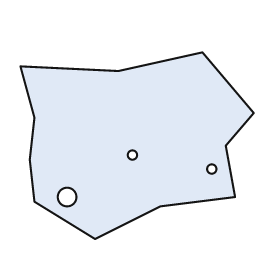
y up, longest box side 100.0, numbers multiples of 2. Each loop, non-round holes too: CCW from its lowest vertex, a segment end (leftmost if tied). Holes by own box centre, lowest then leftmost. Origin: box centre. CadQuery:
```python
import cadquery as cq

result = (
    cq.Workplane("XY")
    .moveTo(-18.0, -40.0)
    .lineTo(10.0, -26.0)
    .lineTo(42.0, -22.0)
    .lineTo(38.0, 0.0)
    .lineTo(50.0, 14.0)
    .lineTo(28.0, 40.0)
    .lineTo(-8.0, 32.0)
    .lineTo(-50.0, 34.0)
    .lineTo(-44.0, 12.0)
    .lineTo(-46.0, -6.0)
    .lineTo(-44.0, -24.0)
    .close()
    .moveTo(-30.0, -22.0)
    .circle(4.0)
    .moveTo(32.0, -10.0)
    .circle(2.0)
    .moveTo(-2.0, -4.0)
    .circle(2.0)
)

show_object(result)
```